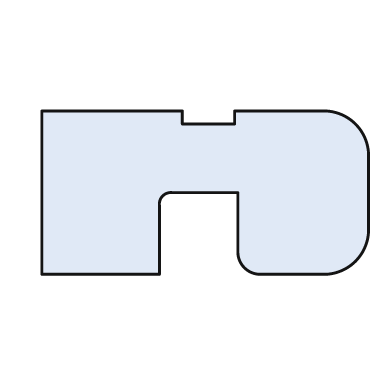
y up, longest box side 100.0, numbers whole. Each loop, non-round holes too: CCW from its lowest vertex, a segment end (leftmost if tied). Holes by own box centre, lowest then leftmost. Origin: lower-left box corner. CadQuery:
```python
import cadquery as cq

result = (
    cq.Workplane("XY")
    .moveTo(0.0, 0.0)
    .lineTo(36.0, 0.0)
    .lineTo(36.0, 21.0)
    .threePointArc((37.0, 24.0), (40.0, 25.0))
    .lineTo(60.0, 25.0)
    .lineTo(60.0, 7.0)
    .threePointArc((62.0, 2.0), (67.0, 0.0))
    .lineTo(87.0, 0.0)
    .threePointArc((96.0, 4.0), (100.0, 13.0))
    .lineTo(100.0, 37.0)
    .threePointArc((96.0, 46.0), (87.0, 50.0))
    .lineTo(59.0, 50.0)
    .lineTo(59.0, 46.0)
    .lineTo(43.0, 46.0)
    .lineTo(43.0, 50.0)
    .lineTo(0.0, 50.0)
    .close()
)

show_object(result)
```